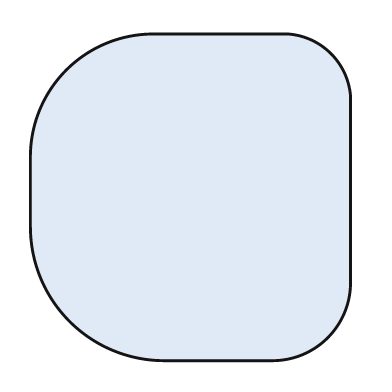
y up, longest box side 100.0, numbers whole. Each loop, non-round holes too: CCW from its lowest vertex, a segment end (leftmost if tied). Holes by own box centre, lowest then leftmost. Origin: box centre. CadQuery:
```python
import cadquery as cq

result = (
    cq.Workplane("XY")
    .moveTo(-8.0, -50.0)
    .lineTo(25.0, -50.0)
    .threePointArc((42.0, -43.0), (49.0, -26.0))
    .lineTo(49.0, 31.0)
    .threePointArc((43.0, 44.0), (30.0, 50.0))
    .lineTo(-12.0, 50.0)
    .threePointArc((-38.0, 39.0), (-49.0, 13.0))
    .lineTo(-49.0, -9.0)
    .threePointArc((-37.0, -38.0), (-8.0, -50.0))
    .close()
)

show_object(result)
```